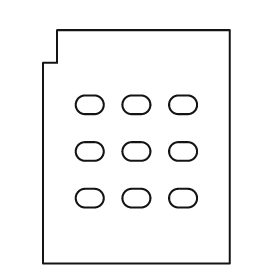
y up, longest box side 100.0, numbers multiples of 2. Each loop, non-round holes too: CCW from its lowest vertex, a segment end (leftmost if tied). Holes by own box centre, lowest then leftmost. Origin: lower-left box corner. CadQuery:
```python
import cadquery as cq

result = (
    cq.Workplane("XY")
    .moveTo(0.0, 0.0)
    .lineTo(80.0, 0.0)
    .lineTo(80.0, 100.0)
    .lineTo(6.0, 100.0)
    .lineTo(6.0, 86.0)
    .lineTo(0.0, 86.0)
    .close()
    .moveTo(18.0, 24.0)
    .lineTo(22.0, 24.0)
    .threePointArc((26.0, 28.0), (22.0, 32.0))
    .lineTo(18.0, 32.0)
    .threePointArc((14.0, 28.0), (18.0, 24.0))
    .close()
    .moveTo(38.0, 24.0)
    .lineTo(42.0, 24.0)
    .threePointArc((46.0, 28.0), (42.0, 32.0))
    .lineTo(38.0, 32.0)
    .threePointArc((34.0, 28.0), (38.0, 24.0))
    .close()
    .moveTo(58.0, 24.0)
    .lineTo(62.0, 24.0)
    .threePointArc((66.0, 28.0), (62.0, 32.0))
    .lineTo(58.0, 32.0)
    .threePointArc((54.0, 28.0), (58.0, 24.0))
    .close()
    .moveTo(18.0, 44.0)
    .lineTo(22.0, 44.0)
    .threePointArc((26.0, 48.0), (22.0, 52.0))
    .lineTo(18.0, 52.0)
    .threePointArc((14.0, 48.0), (18.0, 44.0))
    .close()
    .moveTo(38.0, 44.0)
    .lineTo(42.0, 44.0)
    .threePointArc((46.0, 48.0), (42.0, 52.0))
    .lineTo(38.0, 52.0)
    .threePointArc((34.0, 48.0), (38.0, 44.0))
    .close()
    .moveTo(58.0, 44.0)
    .lineTo(62.0, 44.0)
    .threePointArc((66.0, 48.0), (62.0, 52.0))
    .lineTo(58.0, 52.0)
    .threePointArc((54.0, 48.0), (58.0, 44.0))
    .close()
    .moveTo(18.0, 64.0)
    .lineTo(22.0, 64.0)
    .threePointArc((26.0, 68.0), (22.0, 72.0))
    .lineTo(18.0, 72.0)
    .threePointArc((14.0, 68.0), (18.0, 64.0))
    .close()
    .moveTo(38.0, 64.0)
    .lineTo(42.0, 64.0)
    .threePointArc((46.0, 68.0), (42.0, 72.0))
    .lineTo(38.0, 72.0)
    .threePointArc((34.0, 68.0), (38.0, 64.0))
    .close()
    .moveTo(58.0, 64.0)
    .lineTo(62.0, 64.0)
    .threePointArc((66.0, 68.0), (62.0, 72.0))
    .lineTo(58.0, 72.0)
    .threePointArc((54.0, 68.0), (58.0, 64.0))
    .close()
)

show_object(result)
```